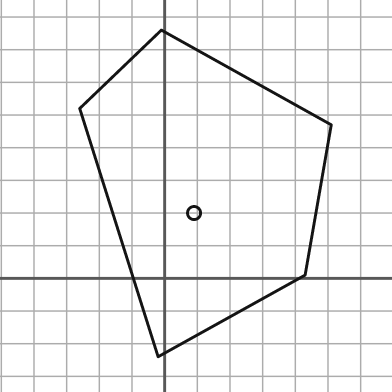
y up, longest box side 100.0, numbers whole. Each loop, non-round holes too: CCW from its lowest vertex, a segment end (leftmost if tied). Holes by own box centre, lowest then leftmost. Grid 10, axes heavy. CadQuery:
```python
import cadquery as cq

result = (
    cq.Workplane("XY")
    .moveTo(-2.0, -24.0)
    .lineTo(43.0, 1.0)
    .lineTo(51.0, 47.0)
    .lineTo(-1.0, 76.0)
    .lineTo(-26.0, 52.0)
    .close()
    .moveTo(9.0, 20.0)
    .circle(2.0)
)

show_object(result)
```